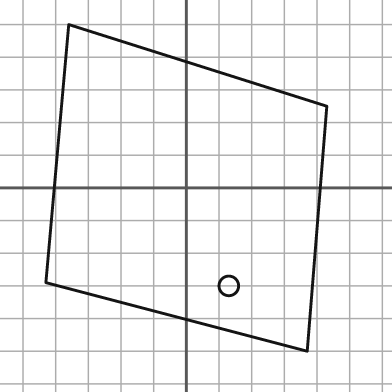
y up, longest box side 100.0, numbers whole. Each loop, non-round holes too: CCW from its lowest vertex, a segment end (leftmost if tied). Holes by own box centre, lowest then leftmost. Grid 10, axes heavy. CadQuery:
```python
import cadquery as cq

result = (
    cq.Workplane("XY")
    .moveTo(37.0, -50.0)
    .lineTo(43.0, 25.0)
    .lineTo(-36.0, 50.0)
    .lineTo(-43.0, -29.0)
    .close()
    .moveTo(13.0, -30.0)
    .circle(3.0)
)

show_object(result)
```